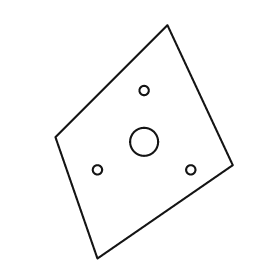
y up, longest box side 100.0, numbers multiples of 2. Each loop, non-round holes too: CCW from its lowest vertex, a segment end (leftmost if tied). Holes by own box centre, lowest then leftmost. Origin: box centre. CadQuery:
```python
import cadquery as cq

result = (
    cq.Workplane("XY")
    .moveTo(-20.0, -50.0)
    .lineTo(38.0, -10.0)
    .lineTo(10.0, 50.0)
    .lineTo(-38.0, 2.0)
    .close()
    .moveTo(-20.0, -12.0)
    .circle(2.0)
    .moveTo(20.0, -12.0)
    .circle(2.0)
    .moveTo(0.0, 0.0)
    .circle(6.0)
    .moveTo(0.0, 22.0)
    .circle(2.0)
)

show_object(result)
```